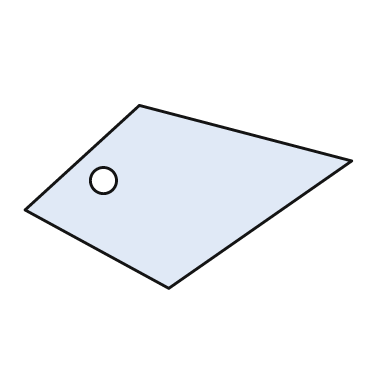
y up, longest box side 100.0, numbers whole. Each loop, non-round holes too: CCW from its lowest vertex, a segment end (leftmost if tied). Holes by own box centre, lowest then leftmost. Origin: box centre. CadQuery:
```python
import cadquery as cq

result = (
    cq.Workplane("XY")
    .moveTo(-6.0, -28.0)
    .lineTo(50.0, 11.0)
    .lineTo(-15.0, 28.0)
    .lineTo(-50.0, -4.0)
    .close()
    .moveTo(-26.0, 5.0)
    .circle(4.0)
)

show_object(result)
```